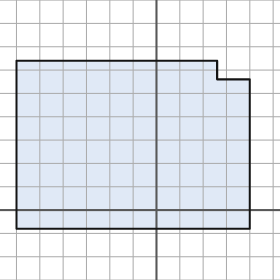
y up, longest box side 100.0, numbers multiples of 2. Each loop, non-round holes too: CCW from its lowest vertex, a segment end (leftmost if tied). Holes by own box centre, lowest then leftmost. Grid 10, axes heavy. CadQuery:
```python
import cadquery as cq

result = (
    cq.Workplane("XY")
    .moveTo(-60.0, -8.0)
    .lineTo(40.0, -8.0)
    .lineTo(40.0, 56.0)
    .lineTo(26.0, 56.0)
    .lineTo(26.0, 64.0)
    .lineTo(-60.0, 64.0)
    .close()
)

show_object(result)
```